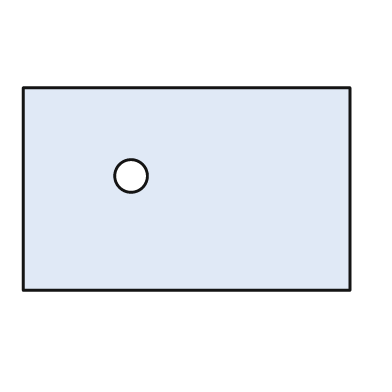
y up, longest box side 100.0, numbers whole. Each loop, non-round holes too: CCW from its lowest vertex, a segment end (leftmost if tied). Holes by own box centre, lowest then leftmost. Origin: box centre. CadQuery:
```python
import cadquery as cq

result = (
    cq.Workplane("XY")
    .moveTo(-50.0, -31.0)
    .lineTo(50.0, -31.0)
    .lineTo(50.0, 31.0)
    .lineTo(-50.0, 31.0)
    .close()
    .moveTo(-17.0, 4.0)
    .circle(5.0)
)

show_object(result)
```